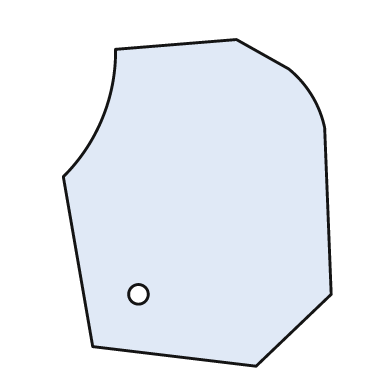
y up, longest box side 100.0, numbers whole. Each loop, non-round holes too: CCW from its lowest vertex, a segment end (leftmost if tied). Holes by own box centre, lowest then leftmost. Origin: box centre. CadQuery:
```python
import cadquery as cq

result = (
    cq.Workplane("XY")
    .moveTo(18.0, -50.0)
    .lineTo(41.0, -28.0)
    .lineTo(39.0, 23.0)
    .threePointArc((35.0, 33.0), (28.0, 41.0))
    .lineTo(12.0, 50.0)
    .lineTo(-25.0, 47.0)
    .threePointArc((-29.0, 26.0), (-41.0, 8.0))
    .lineTo(-32.0, -44.0)
    .close()
    .moveTo(-18.0, -28.0)
    .circle(3.0)
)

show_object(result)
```